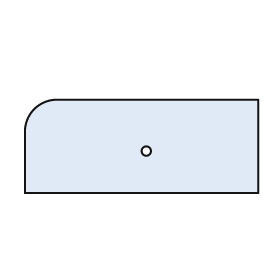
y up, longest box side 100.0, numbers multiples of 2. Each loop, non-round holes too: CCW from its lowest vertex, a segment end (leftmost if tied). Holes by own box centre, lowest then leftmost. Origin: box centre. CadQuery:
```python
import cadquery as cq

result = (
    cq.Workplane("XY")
    .moveTo(-50.0, -20.0)
    .lineTo(50.0, -20.0)
    .lineTo(50.0, 20.0)
    .lineTo(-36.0, 20.0)
    .threePointArc((-46.0, 16.0), (-50.0, 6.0))
    .close()
    .moveTo(2.0, -2.0)
    .circle(2.0)
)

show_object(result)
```